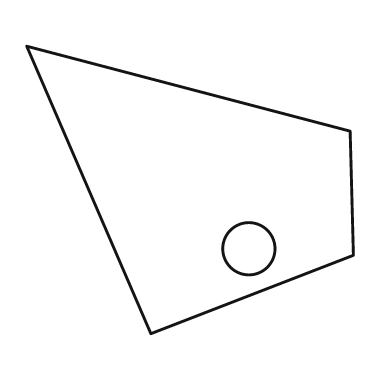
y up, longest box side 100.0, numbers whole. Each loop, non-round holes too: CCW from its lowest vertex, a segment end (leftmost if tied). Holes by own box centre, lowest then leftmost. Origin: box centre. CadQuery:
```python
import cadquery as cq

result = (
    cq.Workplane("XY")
    .moveTo(-12.0, -44.0)
    .lineTo(50.0, -20.0)
    .lineTo(49.0, 18.0)
    .lineTo(-50.0, 44.0)
    .close()
    .moveTo(18.0, -18.0)
    .circle(8.0)
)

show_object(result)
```